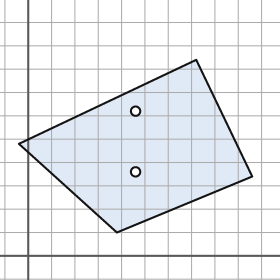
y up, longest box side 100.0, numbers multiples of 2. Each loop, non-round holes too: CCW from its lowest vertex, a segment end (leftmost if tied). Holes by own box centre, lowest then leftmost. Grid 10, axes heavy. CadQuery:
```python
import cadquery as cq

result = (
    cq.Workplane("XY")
    .moveTo(38.0, 10.0)
    .lineTo(96.0, 34.0)
    .lineTo(72.0, 84.0)
    .lineTo(-4.0, 48.0)
    .close()
    .moveTo(46.0, 36.0)
    .circle(2.0)
    .moveTo(46.0, 62.0)
    .circle(2.0)
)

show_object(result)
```